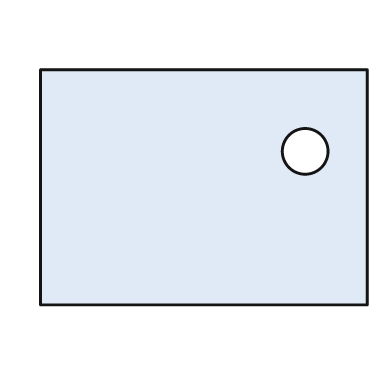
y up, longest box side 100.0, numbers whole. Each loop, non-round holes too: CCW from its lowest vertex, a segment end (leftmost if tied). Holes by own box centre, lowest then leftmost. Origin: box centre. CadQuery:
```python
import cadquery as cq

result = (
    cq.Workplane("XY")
    .moveTo(-50.0, -36.0)
    .lineTo(50.0, -36.0)
    .lineTo(50.0, 36.0)
    .lineTo(-50.0, 36.0)
    .close()
    .moveTo(31.0, 11.0)
    .circle(7.0)
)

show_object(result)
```